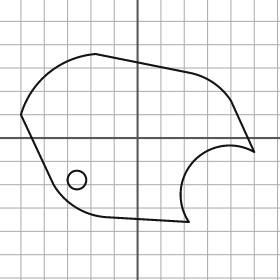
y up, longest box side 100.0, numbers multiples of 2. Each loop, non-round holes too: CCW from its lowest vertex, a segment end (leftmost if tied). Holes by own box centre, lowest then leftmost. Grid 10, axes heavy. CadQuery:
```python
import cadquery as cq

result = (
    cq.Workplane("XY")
    .moveTo(22.0, -36.0)
    .threePointArc((24.0, -10.0), (50.0, -6.0))
    .lineTo(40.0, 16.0)
    .threePointArc((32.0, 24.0), (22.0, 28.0))
    .lineTo(-18.0, 36.0)
    .threePointArc((-38.0, 28.0), (-50.0, 10.0))
    .lineTo(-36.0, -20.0)
    .threePointArc((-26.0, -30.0), (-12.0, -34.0))
    .close()
    .moveTo(-26.0, -18.0)
    .circle(4.0)
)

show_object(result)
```